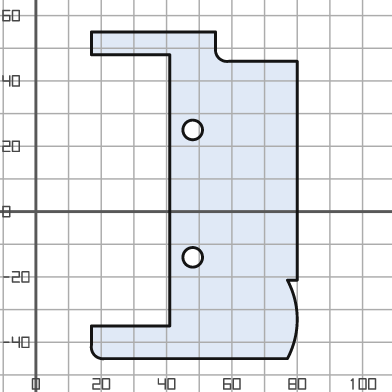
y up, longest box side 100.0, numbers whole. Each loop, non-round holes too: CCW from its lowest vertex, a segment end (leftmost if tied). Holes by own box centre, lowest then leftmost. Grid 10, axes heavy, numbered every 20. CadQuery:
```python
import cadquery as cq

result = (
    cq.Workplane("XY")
    .moveTo(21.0, -45.0)
    .lineTo(77.0, -45.0)
    .threePointArc((80.0, -33.0), (77.0, -21.0))
    .lineTo(80.0, -21.0)
    .lineTo(80.0, 46.0)
    .lineTo(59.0, 46.0)
    .threePointArc((56.0, 47.0), (55.0, 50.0))
    .lineTo(55.0, 55.0)
    .lineTo(17.0, 55.0)
    .lineTo(17.0, 48.0)
    .lineTo(41.0, 48.0)
    .lineTo(41.0, -35.0)
    .lineTo(17.0, -35.0)
    .lineTo(17.0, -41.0)
    .threePointArc((18.0, -44.0), (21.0, -45.0))
    .close()
    .moveTo(48.0, -14.0)
    .circle(3.0)
    .moveTo(48.0, 25.0)
    .circle(3.0)
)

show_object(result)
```